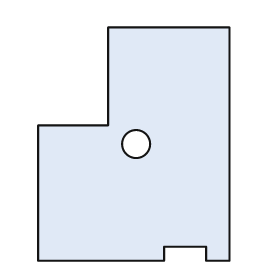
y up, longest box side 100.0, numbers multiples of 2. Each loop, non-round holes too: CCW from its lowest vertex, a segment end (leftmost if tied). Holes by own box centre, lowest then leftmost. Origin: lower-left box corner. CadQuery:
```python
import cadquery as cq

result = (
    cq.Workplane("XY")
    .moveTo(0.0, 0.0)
    .lineTo(54.0, 0.0)
    .lineTo(54.0, 6.0)
    .lineTo(72.0, 6.0)
    .lineTo(72.0, 0.0)
    .lineTo(82.0, 0.0)
    .lineTo(82.0, 100.0)
    .lineTo(30.0, 100.0)
    .lineTo(30.0, 58.0)
    .lineTo(0.0, 58.0)
    .close()
    .moveTo(42.0, 50.0)
    .circle(6.0)
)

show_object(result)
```